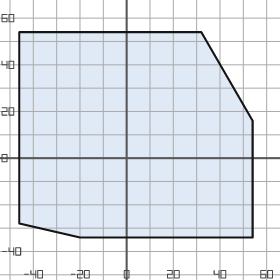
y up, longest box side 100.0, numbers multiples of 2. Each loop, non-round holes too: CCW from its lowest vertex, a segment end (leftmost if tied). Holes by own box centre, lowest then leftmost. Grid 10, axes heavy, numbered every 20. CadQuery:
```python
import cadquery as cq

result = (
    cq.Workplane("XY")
    .moveTo(-20.0, -34.0)
    .lineTo(54.0, -34.0)
    .lineTo(54.0, 16.0)
    .lineTo(32.0, 54.0)
    .lineTo(-46.0, 54.0)
    .lineTo(-46.0, -28.0)
    .close()
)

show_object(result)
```